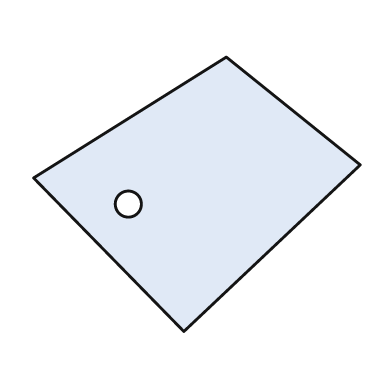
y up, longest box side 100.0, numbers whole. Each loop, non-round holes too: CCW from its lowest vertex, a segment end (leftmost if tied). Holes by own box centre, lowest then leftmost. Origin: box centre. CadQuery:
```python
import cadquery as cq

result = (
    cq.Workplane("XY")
    .moveTo(-4.0, -42.0)
    .lineTo(50.0, 9.0)
    .lineTo(9.0, 42.0)
    .lineTo(-50.0, 5.0)
    .close()
    .moveTo(-21.0, -3.0)
    .circle(4.0)
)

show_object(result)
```